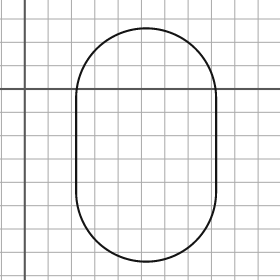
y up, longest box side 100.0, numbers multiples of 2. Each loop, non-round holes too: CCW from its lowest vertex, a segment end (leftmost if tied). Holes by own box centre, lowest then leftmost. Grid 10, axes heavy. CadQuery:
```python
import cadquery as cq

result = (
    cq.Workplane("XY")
    .moveTo(22.0, -44.0)
    .threePointArc((52.0, -74.0), (82.0, -44.0))
    .lineTo(82.0, -4.0)
    .threePointArc((52.0, 26.0), (22.0, -4.0))
    .close()
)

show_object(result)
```